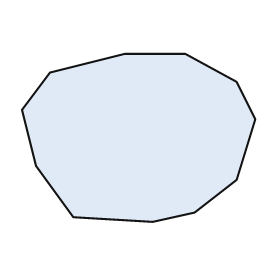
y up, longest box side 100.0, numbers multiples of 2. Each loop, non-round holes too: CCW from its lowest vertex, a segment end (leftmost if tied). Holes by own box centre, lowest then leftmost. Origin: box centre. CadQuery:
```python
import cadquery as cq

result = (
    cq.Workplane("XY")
    .moveTo(6.0, -36.0)
    .lineTo(24.0, -32.0)
    .lineTo(42.0, -18.0)
    .lineTo(50.0, 8.0)
    .lineTo(42.0, 24.0)
    .lineTo(20.0, 36.0)
    .lineTo(-6.0, 36.0)
    .lineTo(-38.0, 28.0)
    .lineTo(-50.0, 12.0)
    .lineTo(-44.0, -12.0)
    .lineTo(-28.0, -34.0)
    .close()
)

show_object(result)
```